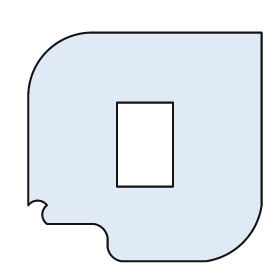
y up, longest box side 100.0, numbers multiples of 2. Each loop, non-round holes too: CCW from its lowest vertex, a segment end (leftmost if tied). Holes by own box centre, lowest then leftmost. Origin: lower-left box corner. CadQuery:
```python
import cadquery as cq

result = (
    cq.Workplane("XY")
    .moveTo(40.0, 0.0)
    .lineTo(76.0, 0.0)
    .threePointArc((92.0, 8.0), (100.0, 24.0))
    .lineTo(100.0, 98.0)
    .lineTo(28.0, 98.0)
    .threePointArc((8.0, 90.0), (0.0, 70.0))
    .lineTo(0.0, 24.0)
    .threePointArc((4.0, 26.0), (8.0, 24.0))
    .threePointArc((6.0, 20.0), (8.0, 16.0))
    .lineTo(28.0, 16.0)
    .threePointArc((32.0, 14.0), (34.0, 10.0))
    .lineTo(34.0, 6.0)
    .threePointArc((36.0, 2.0), (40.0, 0.0))
    .close()
    .moveTo(38.0, 32.0)
    .lineTo(62.0, 32.0)
    .lineTo(62.0, 68.0)
    .lineTo(38.0, 68.0)
    .close()
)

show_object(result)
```